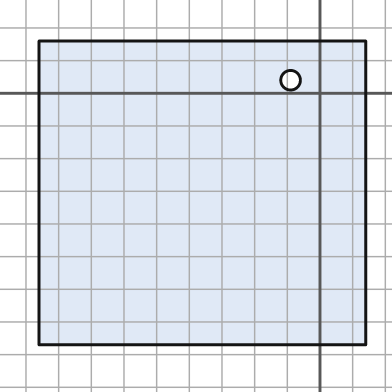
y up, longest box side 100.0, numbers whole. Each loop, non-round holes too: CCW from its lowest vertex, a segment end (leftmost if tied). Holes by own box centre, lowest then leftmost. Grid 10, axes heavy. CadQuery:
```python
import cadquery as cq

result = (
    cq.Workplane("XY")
    .moveTo(-86.0, -77.0)
    .lineTo(14.0, -77.0)
    .lineTo(14.0, 16.0)
    .lineTo(-86.0, 16.0)
    .close()
    .moveTo(-9.0, 4.0)
    .circle(3.0)
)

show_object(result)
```